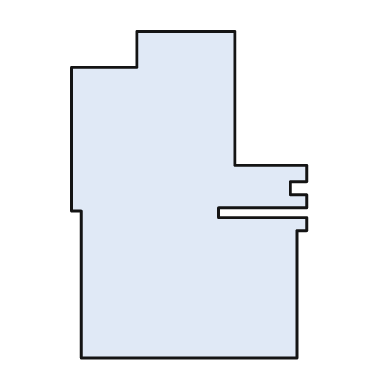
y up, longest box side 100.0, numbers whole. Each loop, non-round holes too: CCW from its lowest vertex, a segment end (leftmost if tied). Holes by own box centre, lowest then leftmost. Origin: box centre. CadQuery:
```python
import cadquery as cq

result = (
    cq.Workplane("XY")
    .moveTo(-33.0, -50.0)
    .lineTo(33.0, -50.0)
    .lineTo(33.0, -11.0)
    .lineTo(36.0, -11.0)
    .lineTo(36.0, -7.0)
    .lineTo(9.0, -7.0)
    .lineTo(9.0, -4.0)
    .lineTo(36.0, -4.0)
    .lineTo(36.0, 0.0)
    .lineTo(31.0, 0.0)
    .lineTo(31.0, 4.0)
    .lineTo(36.0, 4.0)
    .lineTo(36.0, 9.0)
    .lineTo(14.0, 9.0)
    .lineTo(14.0, 50.0)
    .lineTo(-16.0, 50.0)
    .lineTo(-16.0, 39.0)
    .lineTo(-36.0, 39.0)
    .lineTo(-36.0, -5.0)
    .lineTo(-33.0, -5.0)
    .close()
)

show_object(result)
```